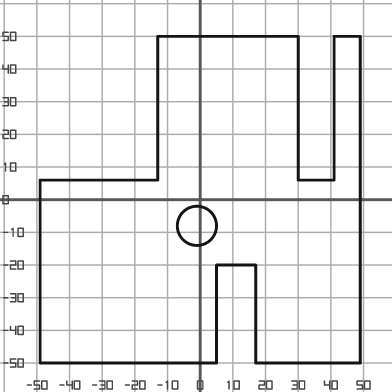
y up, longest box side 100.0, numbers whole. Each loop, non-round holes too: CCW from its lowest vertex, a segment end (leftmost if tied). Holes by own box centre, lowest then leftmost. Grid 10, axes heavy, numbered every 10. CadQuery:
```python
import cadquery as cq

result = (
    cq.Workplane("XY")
    .moveTo(-49.0, -50.0)
    .lineTo(5.0, -50.0)
    .lineTo(5.0, -20.0)
    .lineTo(17.0, -20.0)
    .lineTo(17.0, -50.0)
    .lineTo(49.0, -50.0)
    .lineTo(49.0, 50.0)
    .lineTo(41.0, 50.0)
    .lineTo(41.0, 6.0)
    .lineTo(30.0, 6.0)
    .lineTo(30.0, 50.0)
    .lineTo(-13.0, 50.0)
    .lineTo(-13.0, 6.0)
    .lineTo(-49.0, 6.0)
    .close()
    .moveTo(-1.0, -8.0)
    .circle(6.0)
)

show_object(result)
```